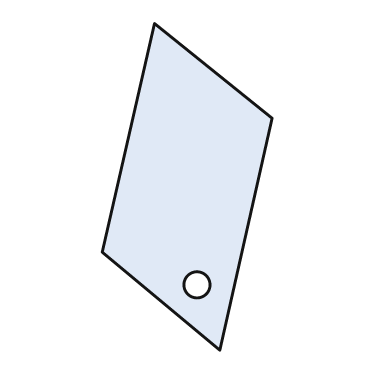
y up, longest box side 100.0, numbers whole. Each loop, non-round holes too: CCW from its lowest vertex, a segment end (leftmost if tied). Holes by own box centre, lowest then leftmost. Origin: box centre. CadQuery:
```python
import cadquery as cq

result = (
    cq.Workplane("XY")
    .moveTo(10.0, -50.0)
    .lineTo(26.0, 21.0)
    .lineTo(-10.0, 50.0)
    .lineTo(-26.0, -20.0)
    .close()
    .moveTo(3.0, -30.0)
    .circle(4.0)
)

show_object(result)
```